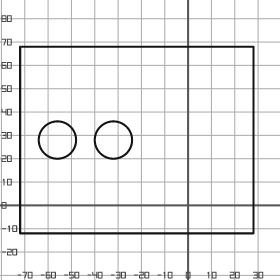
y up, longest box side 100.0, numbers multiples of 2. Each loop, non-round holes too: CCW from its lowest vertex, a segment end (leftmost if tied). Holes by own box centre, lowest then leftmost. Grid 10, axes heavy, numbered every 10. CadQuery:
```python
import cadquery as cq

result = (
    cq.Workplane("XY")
    .moveTo(-72.0, -12.0)
    .lineTo(28.0, -12.0)
    .lineTo(28.0, 68.0)
    .lineTo(-72.0, 68.0)
    .close()
    .moveTo(-56.0, 28.0)
    .circle(8.0)
    .moveTo(-32.0, 28.0)
    .circle(8.0)
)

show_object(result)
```